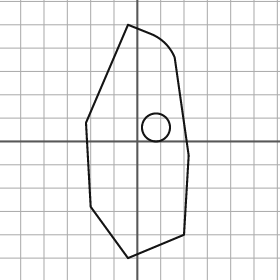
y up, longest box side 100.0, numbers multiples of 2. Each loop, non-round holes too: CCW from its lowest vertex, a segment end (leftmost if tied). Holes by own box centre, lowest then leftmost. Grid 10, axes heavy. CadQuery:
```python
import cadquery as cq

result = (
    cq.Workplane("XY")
    .moveTo(-4.0, -50.0)
    .lineTo(20.0, -40.0)
    .lineTo(22.0, -6.0)
    .lineTo(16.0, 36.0)
    .threePointArc((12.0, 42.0), (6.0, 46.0))
    .lineTo(-4.0, 50.0)
    .lineTo(-22.0, 8.0)
    .lineTo(-20.0, -28.0)
    .close()
    .moveTo(8.0, 6.0)
    .circle(6.0)
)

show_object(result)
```